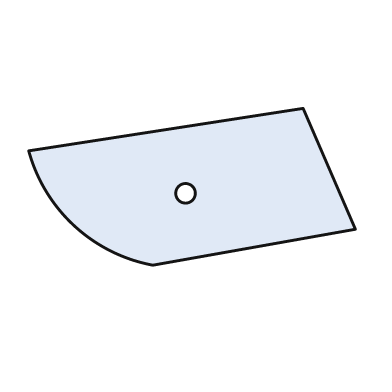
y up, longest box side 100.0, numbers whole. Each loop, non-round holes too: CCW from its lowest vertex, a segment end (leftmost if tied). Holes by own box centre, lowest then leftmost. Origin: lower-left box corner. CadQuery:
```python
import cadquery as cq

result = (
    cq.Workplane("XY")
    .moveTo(38.0, 0.0)
    .lineTo(100.0, 11.0)
    .lineTo(84.0, 48.0)
    .lineTo(0.0, 35.0)
    .threePointArc((14.0, 12.0), (38.0, 0.0))
    .close()
    .moveTo(48.0, 22.0)
    .circle(3.0)
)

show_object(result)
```